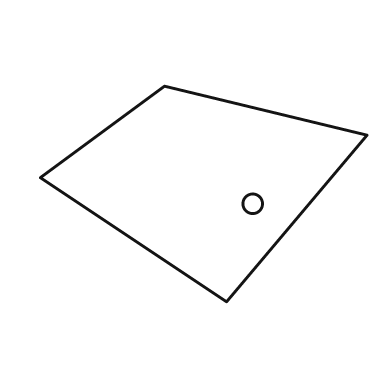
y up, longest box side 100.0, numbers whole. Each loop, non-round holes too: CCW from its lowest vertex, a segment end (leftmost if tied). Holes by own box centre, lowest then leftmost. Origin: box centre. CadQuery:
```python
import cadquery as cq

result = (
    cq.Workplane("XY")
    .moveTo(7.0, -33.0)
    .lineTo(50.0, 18.0)
    .lineTo(-12.0, 33.0)
    .lineTo(-50.0, 5.0)
    .close()
    .moveTo(15.0, -3.0)
    .circle(3.0)
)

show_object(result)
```